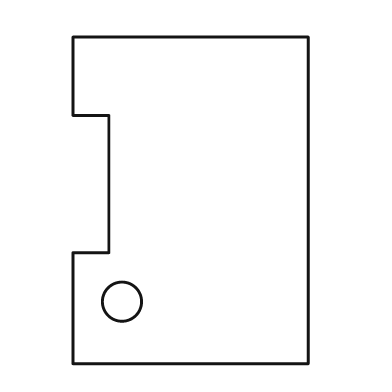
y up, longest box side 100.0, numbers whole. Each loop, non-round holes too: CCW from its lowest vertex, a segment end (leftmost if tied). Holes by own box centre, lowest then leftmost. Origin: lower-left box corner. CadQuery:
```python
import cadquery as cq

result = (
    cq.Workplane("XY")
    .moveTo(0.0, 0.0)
    .lineTo(72.0, 0.0)
    .lineTo(72.0, 100.0)
    .lineTo(0.0, 100.0)
    .lineTo(0.0, 76.0)
    .lineTo(11.0, 76.0)
    .lineTo(11.0, 34.0)
    .lineTo(0.0, 34.0)
    .close()
    .moveTo(15.0, 19.0)
    .circle(6.0)
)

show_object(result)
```